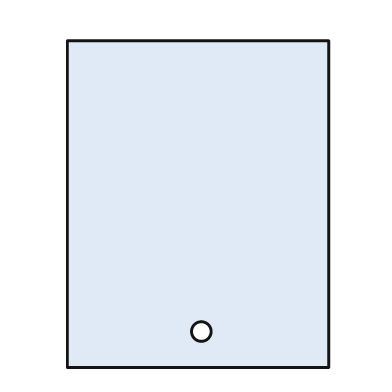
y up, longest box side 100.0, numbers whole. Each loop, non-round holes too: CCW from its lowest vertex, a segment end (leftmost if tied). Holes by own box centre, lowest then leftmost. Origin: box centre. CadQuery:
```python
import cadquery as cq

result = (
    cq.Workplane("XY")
    .moveTo(-40.0, -50.0)
    .lineTo(40.0, -50.0)
    .lineTo(40.0, 50.0)
    .lineTo(-40.0, 50.0)
    .close()
    .moveTo(1.0, -39.0)
    .circle(3.0)
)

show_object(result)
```